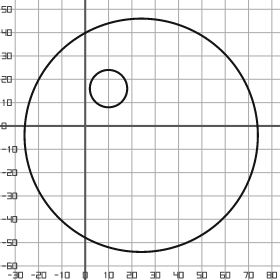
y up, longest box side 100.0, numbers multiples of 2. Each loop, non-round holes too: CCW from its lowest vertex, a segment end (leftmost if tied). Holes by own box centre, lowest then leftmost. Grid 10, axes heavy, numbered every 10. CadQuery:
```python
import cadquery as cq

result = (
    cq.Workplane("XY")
    .moveTo(24.0, -4.0)
    .circle(50.0)
    .moveTo(10.0, 16.0)
    .circle(8.0)
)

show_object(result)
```